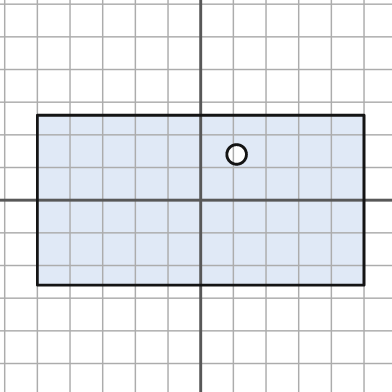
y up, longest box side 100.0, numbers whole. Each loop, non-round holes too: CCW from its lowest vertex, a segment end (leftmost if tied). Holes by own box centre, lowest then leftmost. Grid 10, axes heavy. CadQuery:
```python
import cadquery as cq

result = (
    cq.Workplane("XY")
    .moveTo(-50.0, -26.0)
    .lineTo(50.0, -26.0)
    .lineTo(50.0, 26.0)
    .lineTo(-50.0, 26.0)
    .close()
    .moveTo(11.0, 14.0)
    .circle(3.0)
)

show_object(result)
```